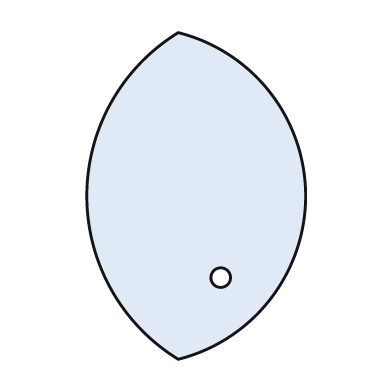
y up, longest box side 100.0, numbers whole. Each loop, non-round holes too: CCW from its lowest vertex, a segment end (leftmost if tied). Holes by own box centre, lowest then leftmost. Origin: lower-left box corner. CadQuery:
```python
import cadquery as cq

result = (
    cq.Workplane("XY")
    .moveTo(28.0, 0.0)
    .threePointArc((67.0, 50.0), (28.0, 100.0))
    .threePointArc((0.0, 50.0), (28.0, 0.0))
    .close()
    .moveTo(41.0, 25.0)
    .circle(3.0)
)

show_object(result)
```